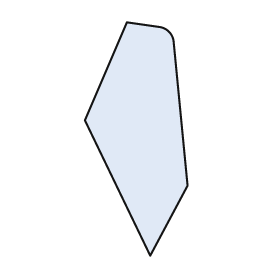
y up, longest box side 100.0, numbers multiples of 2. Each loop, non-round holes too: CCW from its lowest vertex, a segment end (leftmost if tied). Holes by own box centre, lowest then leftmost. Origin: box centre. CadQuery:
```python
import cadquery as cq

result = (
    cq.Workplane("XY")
    .moveTo(6.0, -50.0)
    .lineTo(22.0, -20.0)
    .lineTo(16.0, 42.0)
    .threePointArc((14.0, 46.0), (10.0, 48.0))
    .lineTo(-4.0, 50.0)
    .lineTo(-22.0, 8.0)
    .close()
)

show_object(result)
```